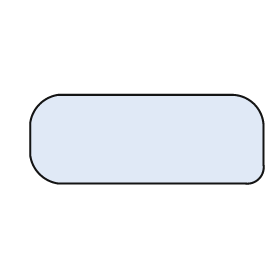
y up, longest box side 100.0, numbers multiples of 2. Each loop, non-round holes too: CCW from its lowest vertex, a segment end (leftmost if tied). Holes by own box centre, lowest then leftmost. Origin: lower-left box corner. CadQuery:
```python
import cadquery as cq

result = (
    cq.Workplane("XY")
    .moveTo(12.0, 0.0)
    .lineTo(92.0, 0.0)
    .threePointArc((98.0, 2.0), (100.0, 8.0))
    .lineTo(100.0, 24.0)
    .threePointArc((96.0, 34.0), (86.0, 38.0))
    .lineTo(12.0, 38.0)
    .threePointArc((4.0, 34.0), (0.0, 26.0))
    .lineTo(0.0, 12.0)
    .threePointArc((4.0, 4.0), (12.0, 0.0))
    .close()
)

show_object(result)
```